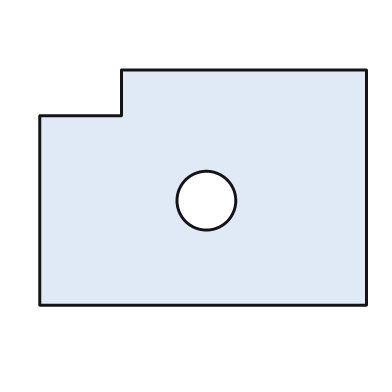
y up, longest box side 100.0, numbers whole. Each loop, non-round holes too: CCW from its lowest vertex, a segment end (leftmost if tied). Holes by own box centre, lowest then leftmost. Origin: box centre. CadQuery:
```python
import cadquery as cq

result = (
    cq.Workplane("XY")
    .moveTo(-50.0, -36.0)
    .lineTo(50.0, -36.0)
    .lineTo(50.0, 36.0)
    .lineTo(-25.0, 36.0)
    .lineTo(-25.0, 22.0)
    .lineTo(-50.0, 22.0)
    .close()
    .moveTo(1.0, -4.0)
    .circle(9.0)
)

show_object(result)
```